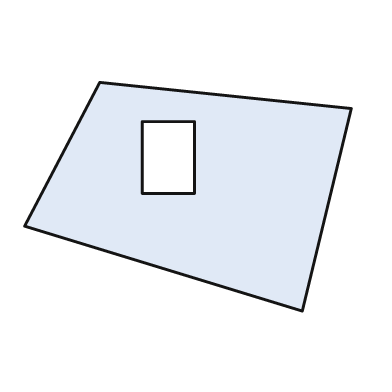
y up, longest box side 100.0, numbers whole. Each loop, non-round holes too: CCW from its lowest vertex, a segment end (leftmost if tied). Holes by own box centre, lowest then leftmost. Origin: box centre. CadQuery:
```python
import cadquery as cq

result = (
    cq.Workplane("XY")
    .moveTo(35.0, -35.0)
    .lineTo(50.0, 27.0)
    .lineTo(-27.0, 35.0)
    .lineTo(-50.0, -9.0)
    .close()
    .moveTo(-14.0, 1.0)
    .lineTo(2.0, 1.0)
    .lineTo(2.0, 23.0)
    .lineTo(-14.0, 23.0)
    .close()
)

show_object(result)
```